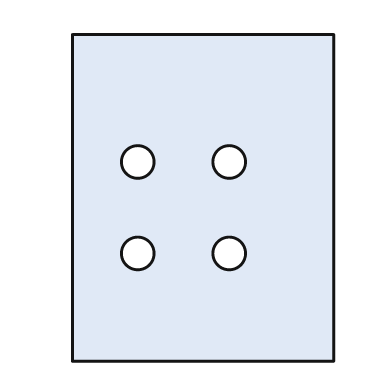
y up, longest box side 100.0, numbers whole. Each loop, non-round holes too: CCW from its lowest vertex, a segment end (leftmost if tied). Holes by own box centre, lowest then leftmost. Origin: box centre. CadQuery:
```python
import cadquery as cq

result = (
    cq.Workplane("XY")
    .moveTo(-40.0, -50.0)
    .lineTo(40.0, -50.0)
    .lineTo(40.0, 50.0)
    .lineTo(-40.0, 50.0)
    .close()
    .moveTo(-20.0, -17.0)
    .circle(5.0)
    .moveTo(8.0, -17.0)
    .circle(5.0)
    .moveTo(-20.0, 11.0)
    .circle(5.0)
    .moveTo(8.0, 11.0)
    .circle(5.0)
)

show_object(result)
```